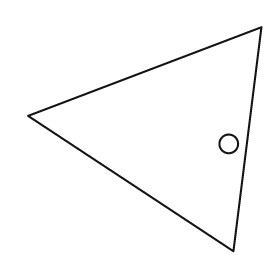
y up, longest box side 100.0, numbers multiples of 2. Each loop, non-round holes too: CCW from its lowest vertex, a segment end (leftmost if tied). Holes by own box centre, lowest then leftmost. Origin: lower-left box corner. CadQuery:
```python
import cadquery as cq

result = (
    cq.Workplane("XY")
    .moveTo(88.0, 0.0)
    .lineTo(100.0, 96.0)
    .lineTo(0.0, 58.0)
    .close()
    .moveTo(86.0, 46.0)
    .circle(4.0)
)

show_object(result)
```